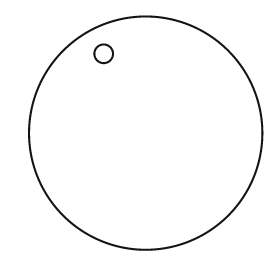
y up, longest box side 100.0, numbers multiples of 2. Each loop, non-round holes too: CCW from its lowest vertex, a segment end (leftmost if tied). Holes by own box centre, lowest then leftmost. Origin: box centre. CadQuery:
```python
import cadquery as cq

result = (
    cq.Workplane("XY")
    .moveTo(0.0, 0.0)
    .circle(50.0)
    .moveTo(-18.0, 34.0)
    .circle(4.0)
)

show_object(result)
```